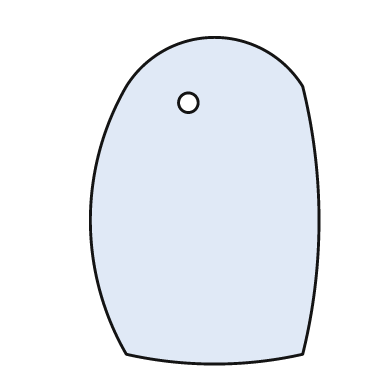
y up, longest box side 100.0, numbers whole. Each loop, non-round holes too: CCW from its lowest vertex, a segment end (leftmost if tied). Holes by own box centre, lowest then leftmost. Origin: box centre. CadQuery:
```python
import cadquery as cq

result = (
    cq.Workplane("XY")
    .moveTo(-24.0, -47.0)
    .threePointArc((3.0, -50.0), (30.0, -47.0))
    .threePointArc((35.0, -6.0), (30.0, 35.0))
    .threePointArc((3.0, 50.0), (-24.0, 35.0))
    .threePointArc((-35.0, -6.0), (-24.0, -47.0))
    .close()
    .moveTo(-5.0, 30.0)
    .circle(3.0)
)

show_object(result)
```